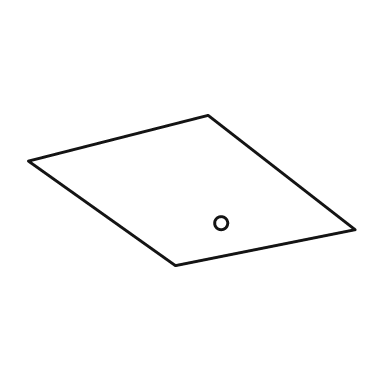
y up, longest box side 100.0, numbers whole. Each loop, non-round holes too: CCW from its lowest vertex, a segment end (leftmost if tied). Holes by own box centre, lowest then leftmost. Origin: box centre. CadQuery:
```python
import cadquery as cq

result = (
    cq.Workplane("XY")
    .moveTo(-5.0, -23.0)
    .lineTo(50.0, -12.0)
    .lineTo(5.0, 23.0)
    .lineTo(-50.0, 9.0)
    .close()
    .moveTo(9.0, -10.0)
    .circle(2.0)
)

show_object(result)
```